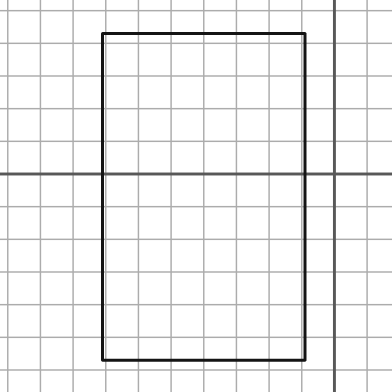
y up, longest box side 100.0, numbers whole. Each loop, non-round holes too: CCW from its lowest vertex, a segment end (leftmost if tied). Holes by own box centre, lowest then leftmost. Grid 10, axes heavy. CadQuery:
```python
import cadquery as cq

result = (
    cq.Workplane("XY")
    .moveTo(-71.0, -57.0)
    .lineTo(-9.0, -57.0)
    .lineTo(-9.0, 43.0)
    .lineTo(-71.0, 43.0)
    .close()
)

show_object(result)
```